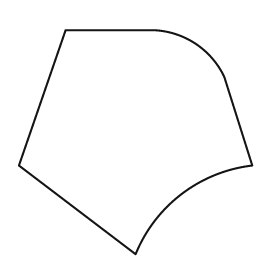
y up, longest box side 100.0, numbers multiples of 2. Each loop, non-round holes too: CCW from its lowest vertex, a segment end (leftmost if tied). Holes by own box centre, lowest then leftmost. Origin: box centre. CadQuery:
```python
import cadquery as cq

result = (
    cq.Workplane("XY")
    .moveTo(0.0, -48.0)
    .threePointArc((20.0, -22.0), (50.0, -10.0))
    .lineTo(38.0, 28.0)
    .threePointArc((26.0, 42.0), (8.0, 48.0))
    .lineTo(-30.0, 48.0)
    .lineTo(-50.0, -10.0)
    .close()
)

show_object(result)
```